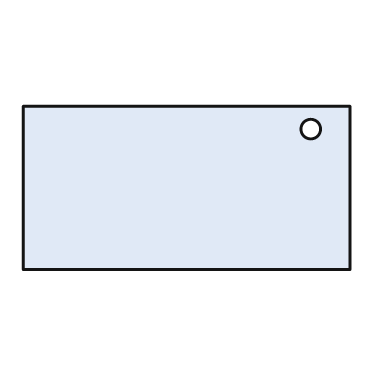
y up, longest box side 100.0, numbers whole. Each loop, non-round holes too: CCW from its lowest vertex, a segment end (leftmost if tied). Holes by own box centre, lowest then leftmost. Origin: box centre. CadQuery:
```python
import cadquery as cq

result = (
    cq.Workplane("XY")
    .moveTo(-50.0, -25.0)
    .lineTo(50.0, -25.0)
    .lineTo(50.0, 25.0)
    .lineTo(-50.0, 25.0)
    .close()
    .moveTo(38.0, 18.0)
    .circle(3.0)
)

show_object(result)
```